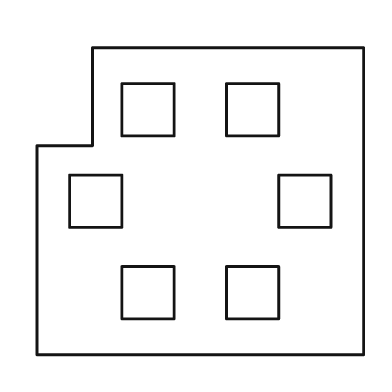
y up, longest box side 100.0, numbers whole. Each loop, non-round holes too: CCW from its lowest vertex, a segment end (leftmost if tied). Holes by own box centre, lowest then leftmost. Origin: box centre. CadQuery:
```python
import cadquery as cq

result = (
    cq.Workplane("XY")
    .moveTo(-50.0, -47.0)
    .lineTo(50.0, -47.0)
    .lineTo(50.0, 47.0)
    .lineTo(-33.0, 47.0)
    .lineTo(-33.0, 17.0)
    .lineTo(-50.0, 17.0)
    .close()
    .moveTo(-24.0, -36.0)
    .lineTo(-8.0, -36.0)
    .lineTo(-8.0, -20.0)
    .lineTo(-24.0, -20.0)
    .close()
    .moveTo(8.0, -36.0)
    .lineTo(24.0, -36.0)
    .lineTo(24.0, -20.0)
    .lineTo(8.0, -20.0)
    .close()
    .moveTo(-40.0, -8.0)
    .lineTo(-24.0, -8.0)
    .lineTo(-24.0, 8.0)
    .lineTo(-40.0, 8.0)
    .close()
    .moveTo(24.0, -8.0)
    .lineTo(40.0, -8.0)
    .lineTo(40.0, 8.0)
    .lineTo(24.0, 8.0)
    .close()
    .moveTo(-24.0, 20.0)
    .lineTo(-8.0, 20.0)
    .lineTo(-8.0, 36.0)
    .lineTo(-24.0, 36.0)
    .close()
    .moveTo(8.0, 20.0)
    .lineTo(24.0, 20.0)
    .lineTo(24.0, 36.0)
    .lineTo(8.0, 36.0)
    .close()
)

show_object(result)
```